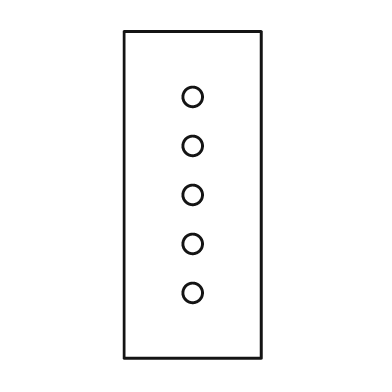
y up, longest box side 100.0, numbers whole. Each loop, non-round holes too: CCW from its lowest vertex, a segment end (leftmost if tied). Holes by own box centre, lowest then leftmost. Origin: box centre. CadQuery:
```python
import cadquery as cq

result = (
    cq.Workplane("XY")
    .moveTo(-21.0, -50.0)
    .lineTo(21.0, -50.0)
    .lineTo(21.0, 50.0)
    .lineTo(-21.0, 50.0)
    .close()
    .moveTo(0.0, -30.0)
    .circle(3.0)
    .moveTo(0.0, -15.0)
    .circle(3.0)
    .moveTo(0.0, 0.0)
    .circle(3.0)
    .moveTo(0.0, 15.0)
    .circle(3.0)
    .moveTo(0.0, 30.0)
    .circle(3.0)
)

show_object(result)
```